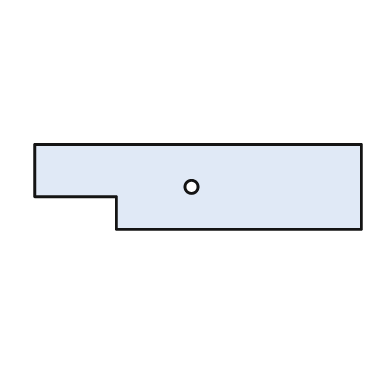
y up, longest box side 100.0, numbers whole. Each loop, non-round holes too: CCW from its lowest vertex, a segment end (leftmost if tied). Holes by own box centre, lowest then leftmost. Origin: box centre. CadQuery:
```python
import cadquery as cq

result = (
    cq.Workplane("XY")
    .moveTo(-25.0, -13.0)
    .lineTo(50.0, -13.0)
    .lineTo(50.0, 13.0)
    .lineTo(-50.0, 13.0)
    .lineTo(-50.0, -3.0)
    .lineTo(-25.0, -3.0)
    .close()
    .moveTo(-2.0, 0.0)
    .circle(2.0)
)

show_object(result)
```